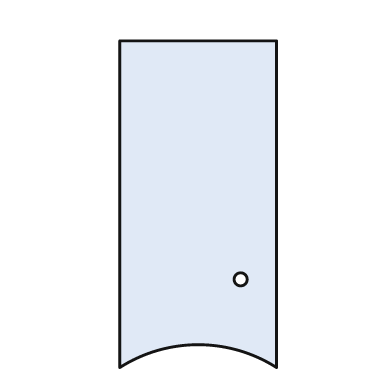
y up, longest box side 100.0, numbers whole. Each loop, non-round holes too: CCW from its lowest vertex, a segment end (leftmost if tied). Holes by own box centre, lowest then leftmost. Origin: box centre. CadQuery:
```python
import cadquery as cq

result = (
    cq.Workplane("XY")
    .moveTo(-24.0, -50.0)
    .threePointArc((0.0, -43.0), (24.0, -50.0))
    .lineTo(24.0, 50.0)
    .lineTo(-24.0, 50.0)
    .close()
    .moveTo(13.0, -23.0)
    .circle(2.0)
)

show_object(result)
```